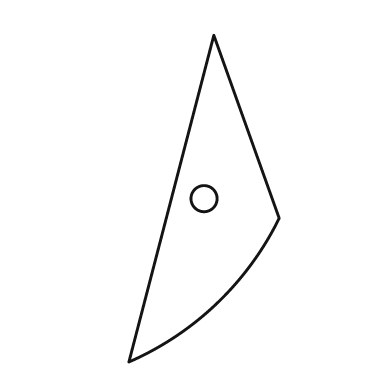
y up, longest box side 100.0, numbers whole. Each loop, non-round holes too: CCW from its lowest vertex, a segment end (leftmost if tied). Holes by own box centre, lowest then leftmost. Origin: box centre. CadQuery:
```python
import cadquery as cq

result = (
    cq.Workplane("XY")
    .moveTo(-23.0, -50.0)
    .threePointArc((4.0, -32.0), (23.0, -6.0))
    .lineTo(3.0, 50.0)
    .close()
    .moveTo(0.0, 0.0)
    .circle(4.0)
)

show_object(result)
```